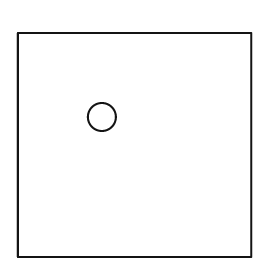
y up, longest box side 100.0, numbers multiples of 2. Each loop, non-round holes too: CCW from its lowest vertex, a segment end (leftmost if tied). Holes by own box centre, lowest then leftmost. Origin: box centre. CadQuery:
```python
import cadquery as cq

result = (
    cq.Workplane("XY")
    .moveTo(-50.0, -48.0)
    .lineTo(50.0, -48.0)
    .lineTo(50.0, 48.0)
    .lineTo(-50.0, 48.0)
    .close()
    .moveTo(-14.0, 12.0)
    .circle(6.0)
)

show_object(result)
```